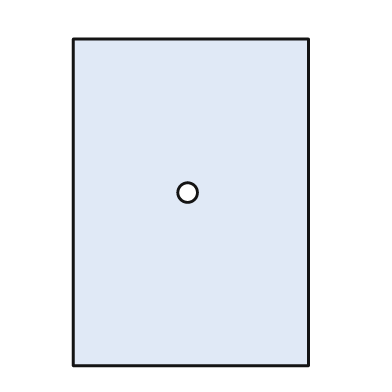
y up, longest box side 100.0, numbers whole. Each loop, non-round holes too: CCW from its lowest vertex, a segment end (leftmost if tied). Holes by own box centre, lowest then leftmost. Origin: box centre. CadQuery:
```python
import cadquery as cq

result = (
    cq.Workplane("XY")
    .moveTo(-36.0, -50.0)
    .lineTo(36.0, -50.0)
    .lineTo(36.0, 50.0)
    .lineTo(-36.0, 50.0)
    .close()
    .moveTo(-1.0, 3.0)
    .circle(3.0)
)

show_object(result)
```